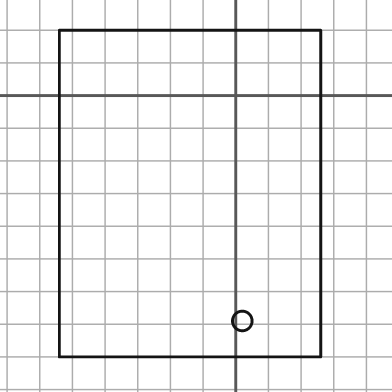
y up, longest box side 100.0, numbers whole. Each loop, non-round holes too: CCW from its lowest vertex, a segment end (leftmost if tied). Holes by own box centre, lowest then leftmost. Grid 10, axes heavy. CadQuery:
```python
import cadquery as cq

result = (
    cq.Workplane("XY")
    .moveTo(-54.0, -80.0)
    .lineTo(26.0, -80.0)
    .lineTo(26.0, 20.0)
    .lineTo(-54.0, 20.0)
    .close()
    .moveTo(2.0, -69.0)
    .circle(3.0)
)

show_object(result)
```